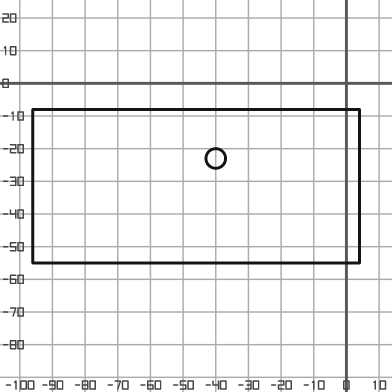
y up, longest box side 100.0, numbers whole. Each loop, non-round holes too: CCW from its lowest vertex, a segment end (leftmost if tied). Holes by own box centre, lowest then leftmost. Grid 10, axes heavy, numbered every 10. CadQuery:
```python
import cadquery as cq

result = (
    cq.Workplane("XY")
    .moveTo(-96.0, -55.0)
    .lineTo(4.0, -55.0)
    .lineTo(4.0, -8.0)
    .lineTo(-96.0, -8.0)
    .close()
    .moveTo(-40.0, -23.0)
    .circle(3.0)
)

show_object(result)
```